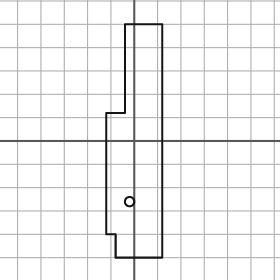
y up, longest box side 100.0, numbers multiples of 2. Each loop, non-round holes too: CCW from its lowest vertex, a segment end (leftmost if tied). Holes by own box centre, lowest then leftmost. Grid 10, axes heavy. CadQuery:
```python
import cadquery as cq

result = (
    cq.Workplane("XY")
    .moveTo(-8.0, -50.0)
    .lineTo(12.0, -50.0)
    .lineTo(12.0, 50.0)
    .lineTo(-4.0, 50.0)
    .lineTo(-4.0, 12.0)
    .lineTo(-12.0, 12.0)
    .lineTo(-12.0, -40.0)
    .lineTo(-8.0, -40.0)
    .close()
    .moveTo(-2.0, -26.0)
    .circle(2.0)
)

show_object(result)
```